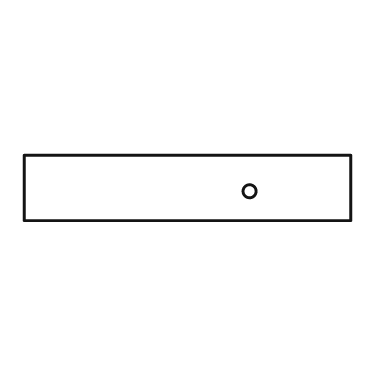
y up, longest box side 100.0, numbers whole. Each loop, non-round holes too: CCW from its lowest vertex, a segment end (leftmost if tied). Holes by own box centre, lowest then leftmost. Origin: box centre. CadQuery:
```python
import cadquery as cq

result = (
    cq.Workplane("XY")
    .moveTo(-50.0, -10.0)
    .lineTo(50.0, -10.0)
    .lineTo(50.0, 10.0)
    .lineTo(-50.0, 10.0)
    .close()
    .moveTo(19.0, -1.0)
    .circle(2.0)
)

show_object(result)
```